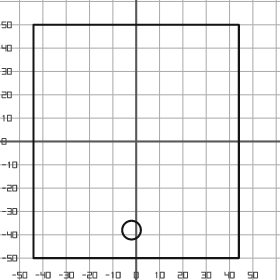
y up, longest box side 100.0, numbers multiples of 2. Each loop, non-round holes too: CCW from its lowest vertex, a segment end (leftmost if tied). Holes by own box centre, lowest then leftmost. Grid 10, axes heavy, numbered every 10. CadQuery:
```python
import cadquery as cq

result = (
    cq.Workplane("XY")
    .moveTo(-44.0, -50.0)
    .lineTo(44.0, -50.0)
    .lineTo(44.0, 50.0)
    .lineTo(-44.0, 50.0)
    .close()
    .moveTo(-2.0, -38.0)
    .circle(4.0)
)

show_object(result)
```